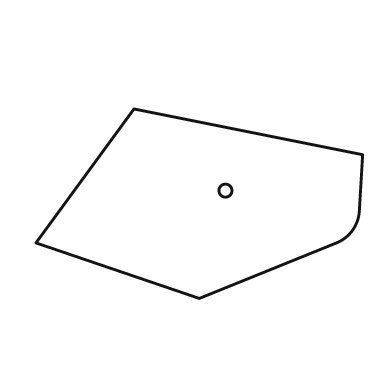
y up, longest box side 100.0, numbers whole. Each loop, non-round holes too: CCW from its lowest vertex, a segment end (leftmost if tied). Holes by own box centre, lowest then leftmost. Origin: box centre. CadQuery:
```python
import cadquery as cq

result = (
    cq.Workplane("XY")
    .moveTo(0.0, -29.0)
    .lineTo(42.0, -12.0)
    .threePointArc((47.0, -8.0), (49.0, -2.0))
    .lineTo(50.0, 15.0)
    .lineTo(-20.0, 29.0)
    .lineTo(-50.0, -12.0)
    .close()
    .moveTo(8.0, 4.0)
    .circle(2.0)
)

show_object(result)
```